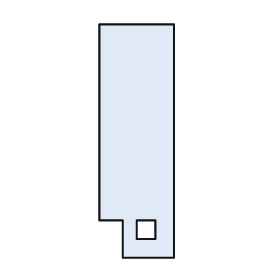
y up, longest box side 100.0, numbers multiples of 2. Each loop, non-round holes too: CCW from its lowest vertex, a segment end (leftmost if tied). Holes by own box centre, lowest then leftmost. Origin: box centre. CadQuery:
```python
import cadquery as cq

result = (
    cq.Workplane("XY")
    .moveTo(-6.0, -50.0)
    .lineTo(16.0, -50.0)
    .lineTo(16.0, 50.0)
    .lineTo(-16.0, 50.0)
    .lineTo(-16.0, -34.0)
    .lineTo(-6.0, -34.0)
    .close()
    .moveTo(0.0, -42.0)
    .lineTo(8.0, -42.0)
    .lineTo(8.0, -34.0)
    .lineTo(0.0, -34.0)
    .close()
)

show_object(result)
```